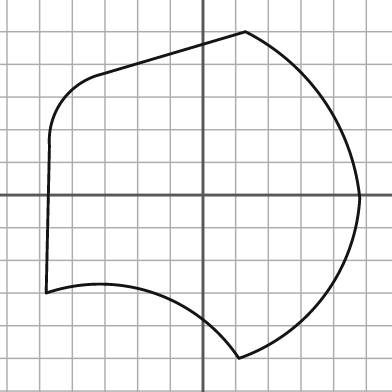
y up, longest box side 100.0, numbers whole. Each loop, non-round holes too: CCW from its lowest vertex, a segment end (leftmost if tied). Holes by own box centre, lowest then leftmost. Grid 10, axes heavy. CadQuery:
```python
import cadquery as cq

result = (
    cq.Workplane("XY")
    .moveTo(11.0, -50.0)
    .threePointArc((37.0, -31.0), (48.0, -1.0))
    .threePointArc((37.0, 29.0), (13.0, 50.0))
    .lineTo(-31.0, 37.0)
    .threePointArc((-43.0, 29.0), (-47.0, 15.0))
    .lineTo(-48.0, -30.0)
    .threePointArc((-15.0, -30.0), (11.0, -50.0))
    .close()
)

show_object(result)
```